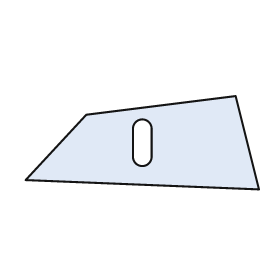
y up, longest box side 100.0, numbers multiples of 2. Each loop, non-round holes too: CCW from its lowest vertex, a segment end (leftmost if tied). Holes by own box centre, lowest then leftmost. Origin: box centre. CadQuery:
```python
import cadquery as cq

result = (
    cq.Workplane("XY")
    .moveTo(50.0, -20.0)
    .lineTo(40.0, 20.0)
    .lineTo(-24.0, 12.0)
    .lineTo(-50.0, -16.0)
    .close()
    .moveTo(-4.0, -6.0)
    .threePointArc((0.0, -10.0), (4.0, -6.0))
    .lineTo(4.0, 6.0)
    .threePointArc((0.0, 10.0), (-4.0, 6.0))
    .close()
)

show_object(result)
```